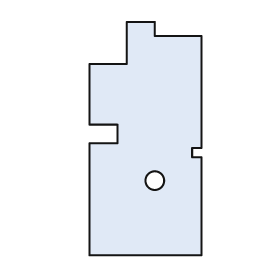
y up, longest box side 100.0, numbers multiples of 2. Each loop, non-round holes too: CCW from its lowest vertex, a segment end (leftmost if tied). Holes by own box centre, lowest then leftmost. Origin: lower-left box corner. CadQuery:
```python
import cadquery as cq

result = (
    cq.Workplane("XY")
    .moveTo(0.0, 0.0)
    .lineTo(48.0, 0.0)
    .lineTo(48.0, 42.0)
    .lineTo(44.0, 42.0)
    .lineTo(44.0, 46.0)
    .lineTo(48.0, 46.0)
    .lineTo(48.0, 94.0)
    .lineTo(28.0, 94.0)
    .lineTo(28.0, 100.0)
    .lineTo(16.0, 100.0)
    .lineTo(16.0, 82.0)
    .lineTo(0.0, 82.0)
    .lineTo(0.0, 56.0)
    .lineTo(12.0, 56.0)
    .lineTo(12.0, 48.0)
    .lineTo(0.0, 48.0)
    .close()
    .moveTo(28.0, 32.0)
    .circle(4.0)
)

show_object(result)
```